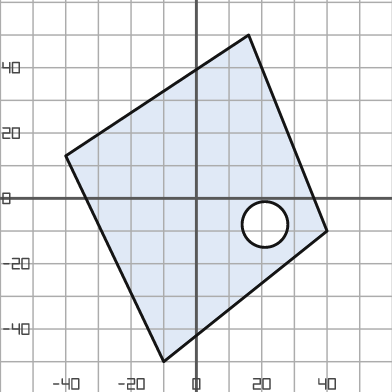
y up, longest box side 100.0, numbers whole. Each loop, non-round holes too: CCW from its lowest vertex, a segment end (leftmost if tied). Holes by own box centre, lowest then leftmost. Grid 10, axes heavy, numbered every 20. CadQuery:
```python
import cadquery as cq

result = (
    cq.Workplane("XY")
    .moveTo(-10.0, -50.0)
    .lineTo(40.0, -10.0)
    .lineTo(16.0, 50.0)
    .lineTo(-40.0, 13.0)
    .close()
    .moveTo(21.0, -8.0)
    .circle(7.0)
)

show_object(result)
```